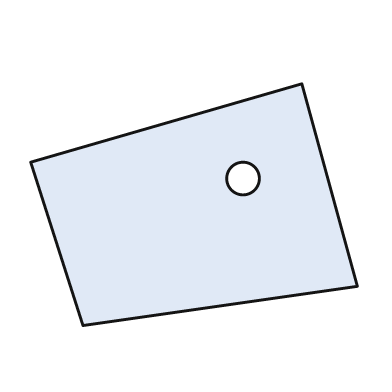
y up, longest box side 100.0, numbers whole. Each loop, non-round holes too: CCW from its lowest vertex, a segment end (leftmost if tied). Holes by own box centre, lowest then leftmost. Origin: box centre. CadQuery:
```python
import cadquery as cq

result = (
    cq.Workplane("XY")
    .moveTo(-34.0, -37.0)
    .lineTo(50.0, -25.0)
    .lineTo(33.0, 37.0)
    .lineTo(-50.0, 13.0)
    .close()
    .moveTo(15.0, 8.0)
    .circle(5.0)
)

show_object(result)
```